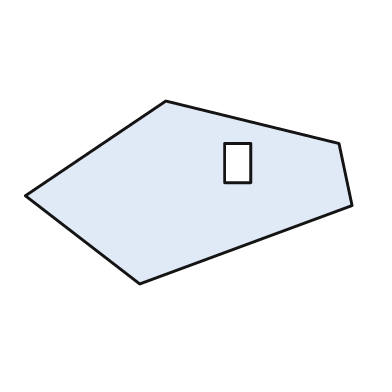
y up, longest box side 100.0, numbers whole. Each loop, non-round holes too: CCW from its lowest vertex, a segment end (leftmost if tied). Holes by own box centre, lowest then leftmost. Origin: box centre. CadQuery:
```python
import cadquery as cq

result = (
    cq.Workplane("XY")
    .moveTo(-15.0, -28.0)
    .lineTo(50.0, -4.0)
    .lineTo(46.0, 15.0)
    .lineTo(-7.0, 28.0)
    .lineTo(-50.0, -1.0)
    .close()
    .moveTo(11.0, 3.0)
    .lineTo(19.0, 3.0)
    .lineTo(19.0, 15.0)
    .lineTo(11.0, 15.0)
    .close()
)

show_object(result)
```